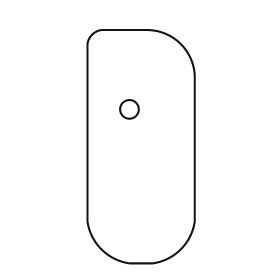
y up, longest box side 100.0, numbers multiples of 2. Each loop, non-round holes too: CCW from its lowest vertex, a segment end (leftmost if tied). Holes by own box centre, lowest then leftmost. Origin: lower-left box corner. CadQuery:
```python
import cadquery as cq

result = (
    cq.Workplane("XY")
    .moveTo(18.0, 0.0)
    .lineTo(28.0, 0.0)
    .threePointArc((40.0, 6.0), (46.0, 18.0))
    .lineTo(46.0, 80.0)
    .threePointArc((40.0, 94.0), (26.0, 100.0))
    .lineTo(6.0, 100.0)
    .threePointArc((2.0, 98.0), (0.0, 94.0))
    .lineTo(0.0, 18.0)
    .threePointArc((6.0, 6.0), (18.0, 0.0))
    .close()
    .moveTo(18.0, 66.0)
    .circle(4.0)
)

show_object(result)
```